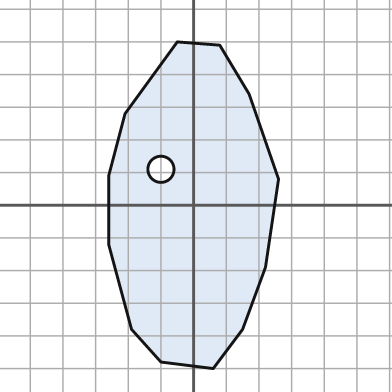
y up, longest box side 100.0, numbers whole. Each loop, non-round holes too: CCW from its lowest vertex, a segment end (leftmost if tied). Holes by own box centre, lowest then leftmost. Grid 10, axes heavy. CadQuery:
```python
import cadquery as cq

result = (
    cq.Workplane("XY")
    .moveTo(6.0, -50.0)
    .lineTo(15.0, -38.0)
    .lineTo(22.0, -19.0)
    .lineTo(26.0, 8.0)
    .lineTo(17.0, 34.0)
    .lineTo(8.0, 49.0)
    .lineTo(-5.0, 50.0)
    .lineTo(-21.0, 28.0)
    .lineTo(-26.0, 9.0)
    .lineTo(-26.0, -12.0)
    .lineTo(-19.0, -38.0)
    .lineTo(-10.0, -48.0)
    .close()
    .moveTo(-10.0, 11.0)
    .circle(4.0)
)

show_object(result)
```